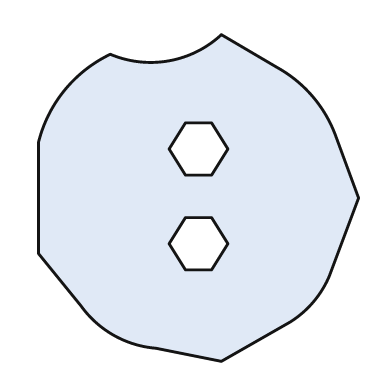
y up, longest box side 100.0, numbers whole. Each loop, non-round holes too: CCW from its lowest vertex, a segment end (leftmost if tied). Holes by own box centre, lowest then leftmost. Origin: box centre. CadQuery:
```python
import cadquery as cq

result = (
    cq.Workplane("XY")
    .moveTo(7.0, -50.0)
    .lineTo(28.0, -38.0)
    .threePointArc((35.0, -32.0), (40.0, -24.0))
    .lineTo(49.0, 0.0)
    .lineTo(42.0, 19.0)
    .threePointArc((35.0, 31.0), (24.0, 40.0))
    .lineTo(7.0, 50.0)
    .threePointArc((-9.0, 42.0), (-27.0, 44.0))
    .threePointArc((-41.0, 33.0), (-49.0, 17.0))
    .lineTo(-49.0, -17.0)
    .lineTo(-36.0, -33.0)
    .threePointArc((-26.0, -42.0), (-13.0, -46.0))
    .close()
    .moveTo(-4.0, -22.0)
    .lineTo(4.0, -22.0)
    .lineTo(9.0, -14.0)
    .lineTo(4.0, -6.0)
    .lineTo(-4.0, -6.0)
    .lineTo(-9.0, -14.0)
    .close()
    .moveTo(-4.0, 7.0)
    .lineTo(4.0, 7.0)
    .lineTo(9.0, 15.0)
    .lineTo(4.0, 23.0)
    .lineTo(-4.0, 23.0)
    .lineTo(-9.0, 15.0)
    .close()
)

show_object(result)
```